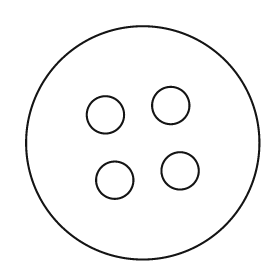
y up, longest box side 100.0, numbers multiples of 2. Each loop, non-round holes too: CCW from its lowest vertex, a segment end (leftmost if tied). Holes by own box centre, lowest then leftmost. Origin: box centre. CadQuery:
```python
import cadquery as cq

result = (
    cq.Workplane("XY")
    .moveTo(0.0, 0.0)
    .circle(50.0)
    .moveTo(-12.0, -16.0)
    .circle(8.0)
    .moveTo(16.0, -12.0)
    .circle(8.0)
    .moveTo(-16.0, 12.0)
    .circle(8.0)
    .moveTo(12.0, 16.0)
    .circle(8.0)
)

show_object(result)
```